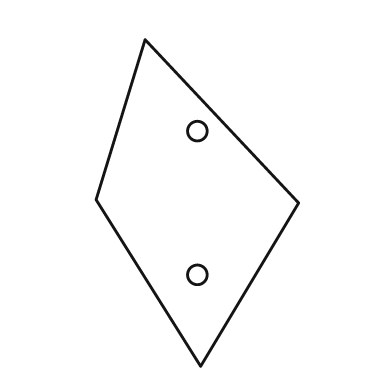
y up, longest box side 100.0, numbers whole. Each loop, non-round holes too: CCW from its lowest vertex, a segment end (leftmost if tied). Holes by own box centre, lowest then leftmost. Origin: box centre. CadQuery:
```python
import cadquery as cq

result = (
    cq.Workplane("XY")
    .moveTo(1.0, -50.0)
    .lineTo(31.0, 0.0)
    .lineTo(-16.0, 50.0)
    .lineTo(-31.0, 1.0)
    .close()
    .moveTo(0.0, -22.0)
    .circle(3.0)
    .moveTo(0.0, 22.0)
    .circle(3.0)
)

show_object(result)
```